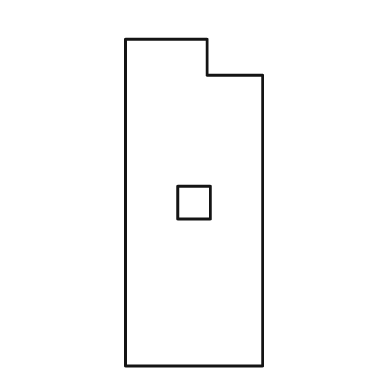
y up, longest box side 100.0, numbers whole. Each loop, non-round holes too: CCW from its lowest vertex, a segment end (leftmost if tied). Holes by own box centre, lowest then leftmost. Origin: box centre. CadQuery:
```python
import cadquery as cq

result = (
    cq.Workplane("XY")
    .moveTo(-21.0, -50.0)
    .lineTo(21.0, -50.0)
    .lineTo(21.0, 39.0)
    .lineTo(4.0, 39.0)
    .lineTo(4.0, 50.0)
    .lineTo(-21.0, 50.0)
    .close()
    .moveTo(-5.0, -5.0)
    .lineTo(5.0, -5.0)
    .lineTo(5.0, 5.0)
    .lineTo(-5.0, 5.0)
    .close()
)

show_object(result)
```